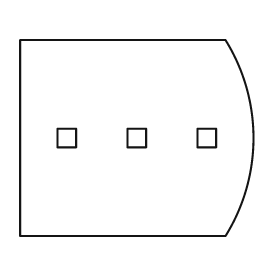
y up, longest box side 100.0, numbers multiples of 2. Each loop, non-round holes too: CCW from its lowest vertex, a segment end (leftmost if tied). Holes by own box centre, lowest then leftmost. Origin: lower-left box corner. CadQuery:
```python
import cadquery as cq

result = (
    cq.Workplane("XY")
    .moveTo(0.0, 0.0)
    .lineTo(88.0, 0.0)
    .threePointArc((100.0, 42.0), (88.0, 84.0))
    .lineTo(0.0, 84.0)
    .close()
    .moveTo(16.0, 38.0)
    .lineTo(24.0, 38.0)
    .lineTo(24.0, 46.0)
    .lineTo(16.0, 46.0)
    .close()
    .moveTo(46.0, 38.0)
    .lineTo(54.0, 38.0)
    .lineTo(54.0, 46.0)
    .lineTo(46.0, 46.0)
    .close()
    .moveTo(76.0, 38.0)
    .lineTo(84.0, 38.0)
    .lineTo(84.0, 46.0)
    .lineTo(76.0, 46.0)
    .close()
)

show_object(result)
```